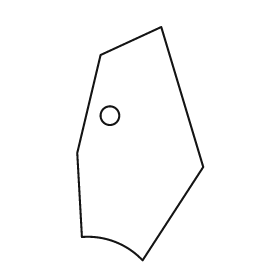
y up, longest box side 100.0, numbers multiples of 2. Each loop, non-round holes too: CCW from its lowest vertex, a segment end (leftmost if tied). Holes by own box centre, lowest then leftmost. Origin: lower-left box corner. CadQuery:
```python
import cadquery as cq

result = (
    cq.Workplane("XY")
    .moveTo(28.0, 0.0)
    .lineTo(54.0, 40.0)
    .lineTo(36.0, 100.0)
    .lineTo(10.0, 88.0)
    .lineTo(0.0, 46.0)
    .lineTo(2.0, 10.0)
    .threePointArc((16.0, 8.0), (28.0, 0.0))
    .close()
    .moveTo(14.0, 62.0)
    .circle(4.0)
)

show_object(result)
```